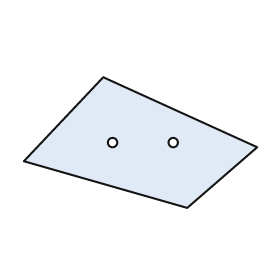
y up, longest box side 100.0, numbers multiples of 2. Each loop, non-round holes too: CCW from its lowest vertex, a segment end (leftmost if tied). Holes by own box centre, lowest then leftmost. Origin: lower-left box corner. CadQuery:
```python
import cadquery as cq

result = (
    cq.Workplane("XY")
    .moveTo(70.0, 0.0)
    .lineTo(100.0, 26.0)
    .lineTo(34.0, 56.0)
    .lineTo(0.0, 20.0)
    .close()
    .moveTo(38.0, 28.0)
    .circle(2.0)
    .moveTo(64.0, 28.0)
    .circle(2.0)
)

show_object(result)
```